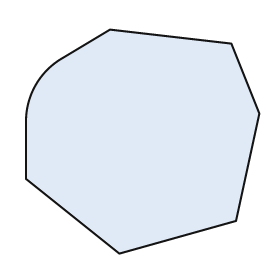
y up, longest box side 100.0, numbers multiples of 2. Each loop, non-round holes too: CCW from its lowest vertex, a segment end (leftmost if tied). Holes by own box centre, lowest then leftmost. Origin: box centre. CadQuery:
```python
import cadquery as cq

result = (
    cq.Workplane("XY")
    .moveTo(-10.0, -48.0)
    .lineTo(40.0, -34.0)
    .lineTo(50.0, 12.0)
    .lineTo(38.0, 42.0)
    .lineTo(-14.0, 48.0)
    .lineTo(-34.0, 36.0)
    .threePointArc((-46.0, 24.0), (-50.0, 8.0))
    .lineTo(-50.0, -16.0)
    .close()
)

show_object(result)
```